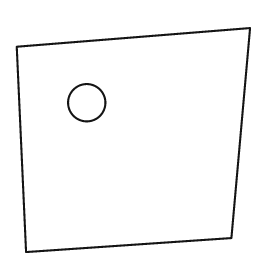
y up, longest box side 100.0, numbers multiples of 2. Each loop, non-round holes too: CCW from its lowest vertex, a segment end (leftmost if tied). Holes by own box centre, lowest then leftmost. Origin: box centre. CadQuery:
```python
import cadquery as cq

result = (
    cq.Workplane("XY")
    .moveTo(-46.0, -48.0)
    .lineTo(42.0, -42.0)
    .lineTo(50.0, 48.0)
    .lineTo(-50.0, 40.0)
    .close()
    .moveTo(-20.0, 16.0)
    .circle(8.0)
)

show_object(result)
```